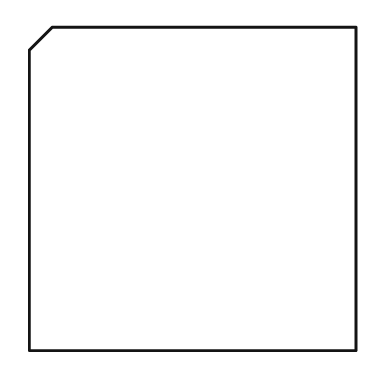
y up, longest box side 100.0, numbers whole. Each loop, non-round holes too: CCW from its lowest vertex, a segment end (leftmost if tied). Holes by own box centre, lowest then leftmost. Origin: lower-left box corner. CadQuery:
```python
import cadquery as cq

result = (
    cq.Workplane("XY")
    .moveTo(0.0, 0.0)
    .lineTo(100.0, 0.0)
    .lineTo(100.0, 99.0)
    .lineTo(7.0, 99.0)
    .lineTo(0.0, 92.0)
    .close()
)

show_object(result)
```